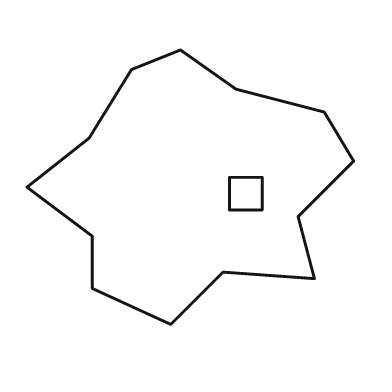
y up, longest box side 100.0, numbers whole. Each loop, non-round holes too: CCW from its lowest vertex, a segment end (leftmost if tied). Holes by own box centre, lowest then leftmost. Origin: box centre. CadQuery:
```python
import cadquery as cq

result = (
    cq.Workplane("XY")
    .moveTo(-6.0, -42.0)
    .lineTo(10.0, -26.0)
    .lineTo(38.0, -28.0)
    .lineTo(33.0, -9.0)
    .lineTo(50.0, 8.0)
    .lineTo(41.0, 23.0)
    .lineTo(14.0, 30.0)
    .lineTo(-3.0, 42.0)
    .lineTo(-18.0, 36.0)
    .lineTo(-31.0, 15.0)
    .lineTo(-50.0, 0.0)
    .lineTo(-30.0, -15.0)
    .lineTo(-30.0, -31.0)
    .close()
    .moveTo(12.0, -7.0)
    .lineTo(22.0, -7.0)
    .lineTo(22.0, 3.0)
    .lineTo(12.0, 3.0)
    .close()
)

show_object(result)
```